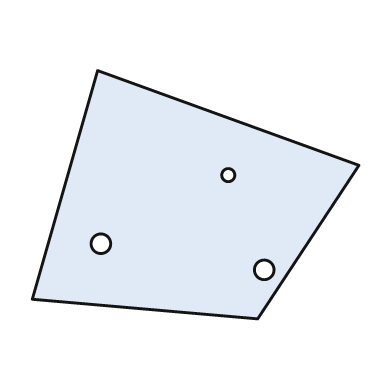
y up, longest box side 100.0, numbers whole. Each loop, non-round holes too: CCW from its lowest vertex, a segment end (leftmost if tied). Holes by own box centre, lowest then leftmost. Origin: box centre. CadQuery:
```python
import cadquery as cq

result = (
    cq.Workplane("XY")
    .moveTo(19.0, -38.0)
    .lineTo(50.0, 9.0)
    .lineTo(-30.0, 38.0)
    .lineTo(-50.0, -32.0)
    .close()
    .moveTo(21.0, -23.0)
    .circle(3.0)
    .moveTo(-29.0, -15.0)
    .circle(3.0)
    .moveTo(10.0, 6.0)
    .circle(2.0)
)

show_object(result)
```